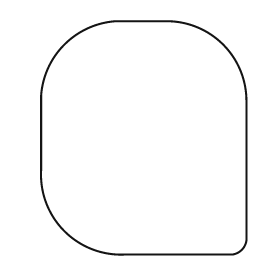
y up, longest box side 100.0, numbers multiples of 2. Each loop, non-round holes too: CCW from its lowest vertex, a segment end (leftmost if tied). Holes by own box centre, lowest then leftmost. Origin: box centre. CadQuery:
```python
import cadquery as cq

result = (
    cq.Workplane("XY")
    .moveTo(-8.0, -50.0)
    .lineTo(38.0, -50.0)
    .threePointArc((42.0, -48.0), (44.0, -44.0))
    .lineTo(44.0, 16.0)
    .threePointArc((34.0, 40.0), (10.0, 50.0))
    .lineTo(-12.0, 50.0)
    .threePointArc((-34.0, 40.0), (-44.0, 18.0))
    .lineTo(-44.0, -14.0)
    .threePointArc((-34.0, -40.0), (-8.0, -50.0))
    .close()
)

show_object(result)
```